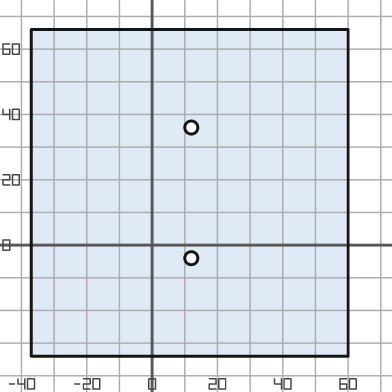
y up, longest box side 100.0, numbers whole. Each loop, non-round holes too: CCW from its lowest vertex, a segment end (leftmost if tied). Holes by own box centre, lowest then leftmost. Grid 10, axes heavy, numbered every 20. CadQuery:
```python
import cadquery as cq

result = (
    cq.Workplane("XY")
    .moveTo(-37.0, -34.0)
    .lineTo(60.0, -34.0)
    .lineTo(60.0, 66.0)
    .lineTo(-37.0, 66.0)
    .close()
    .moveTo(12.0, -4.0)
    .circle(2.0)
    .moveTo(12.0, 36.0)
    .circle(2.0)
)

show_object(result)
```